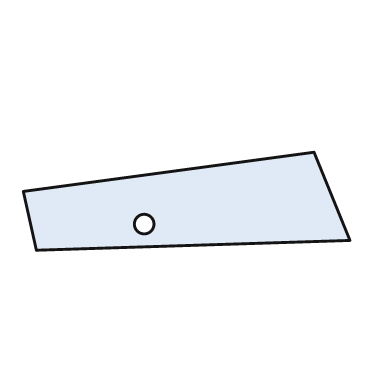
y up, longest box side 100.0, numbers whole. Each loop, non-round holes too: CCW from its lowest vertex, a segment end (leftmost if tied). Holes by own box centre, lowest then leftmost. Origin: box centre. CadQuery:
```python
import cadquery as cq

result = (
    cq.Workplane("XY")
    .moveTo(-46.0, -15.0)
    .lineTo(50.0, -12.0)
    .lineTo(39.0, 15.0)
    .lineTo(-50.0, 3.0)
    .close()
    .moveTo(-13.0, -7.0)
    .circle(3.0)
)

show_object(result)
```